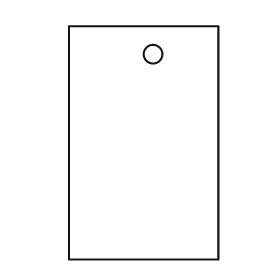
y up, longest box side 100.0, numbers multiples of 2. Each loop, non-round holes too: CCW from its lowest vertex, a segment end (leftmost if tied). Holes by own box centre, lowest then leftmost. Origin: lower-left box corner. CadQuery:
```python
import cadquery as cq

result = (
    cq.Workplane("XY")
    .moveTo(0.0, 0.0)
    .lineTo(64.0, 0.0)
    .lineTo(64.0, 100.0)
    .lineTo(0.0, 100.0)
    .close()
    .moveTo(36.0, 88.0)
    .circle(4.0)
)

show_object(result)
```